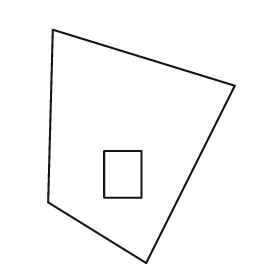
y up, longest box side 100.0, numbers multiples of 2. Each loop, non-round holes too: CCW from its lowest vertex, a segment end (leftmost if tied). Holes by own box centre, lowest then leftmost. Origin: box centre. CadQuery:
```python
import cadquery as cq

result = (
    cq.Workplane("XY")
    .moveTo(2.0, -50.0)
    .lineTo(40.0, 26.0)
    .lineTo(-38.0, 50.0)
    .lineTo(-40.0, -24.0)
    .close()
    .moveTo(-16.0, -22.0)
    .lineTo(0.0, -22.0)
    .lineTo(0.0, -2.0)
    .lineTo(-16.0, -2.0)
    .close()
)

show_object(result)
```